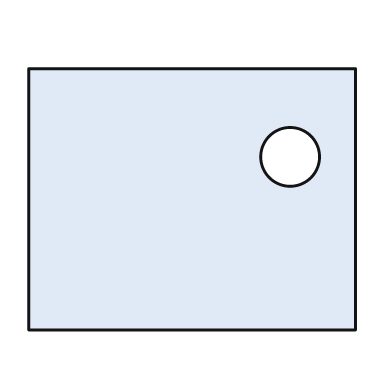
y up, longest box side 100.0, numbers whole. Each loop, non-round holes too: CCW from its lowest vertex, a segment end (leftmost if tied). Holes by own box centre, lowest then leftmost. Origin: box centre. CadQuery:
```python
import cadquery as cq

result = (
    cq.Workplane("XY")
    .moveTo(-50.0, -40.0)
    .lineTo(50.0, -40.0)
    .lineTo(50.0, 40.0)
    .lineTo(-50.0, 40.0)
    .close()
    .moveTo(30.0, 13.0)
    .circle(9.0)
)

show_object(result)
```